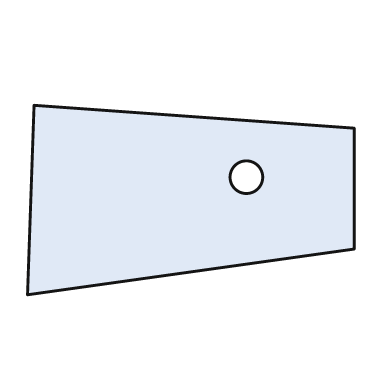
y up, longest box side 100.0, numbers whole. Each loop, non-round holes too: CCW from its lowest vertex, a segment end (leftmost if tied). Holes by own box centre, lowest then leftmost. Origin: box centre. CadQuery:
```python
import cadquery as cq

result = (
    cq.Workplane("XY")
    .moveTo(-50.0, -29.0)
    .lineTo(50.0, -15.0)
    .lineTo(50.0, 22.0)
    .lineTo(-48.0, 29.0)
    .close()
    .moveTo(17.0, 7.0)
    .circle(5.0)
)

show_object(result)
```